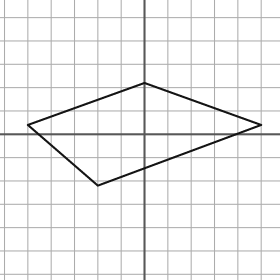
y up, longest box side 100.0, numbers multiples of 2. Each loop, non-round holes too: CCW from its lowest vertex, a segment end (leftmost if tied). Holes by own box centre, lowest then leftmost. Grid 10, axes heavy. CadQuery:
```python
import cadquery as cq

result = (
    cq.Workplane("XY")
    .moveTo(-20.0, -22.0)
    .lineTo(50.0, 4.0)
    .lineTo(0.0, 22.0)
    .lineTo(-50.0, 4.0)
    .close()
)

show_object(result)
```